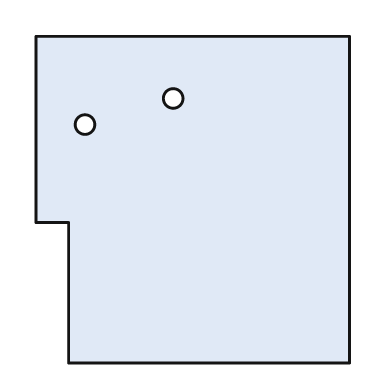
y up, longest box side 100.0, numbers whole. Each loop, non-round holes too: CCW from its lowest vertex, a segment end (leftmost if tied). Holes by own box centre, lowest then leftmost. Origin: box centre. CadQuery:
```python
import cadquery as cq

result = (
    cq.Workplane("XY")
    .moveTo(-38.0, -50.0)
    .lineTo(48.0, -50.0)
    .lineTo(48.0, 50.0)
    .lineTo(-48.0, 50.0)
    .lineTo(-48.0, -7.0)
    .lineTo(-38.0, -7.0)
    .close()
    .moveTo(-33.0, 23.0)
    .circle(3.0)
    .moveTo(-6.0, 31.0)
    .circle(3.0)
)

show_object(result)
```